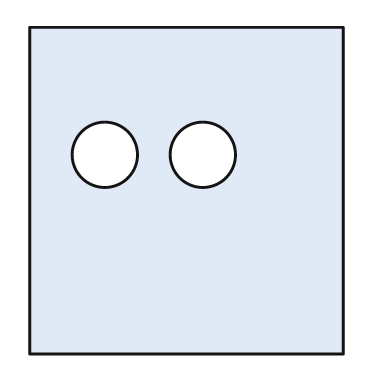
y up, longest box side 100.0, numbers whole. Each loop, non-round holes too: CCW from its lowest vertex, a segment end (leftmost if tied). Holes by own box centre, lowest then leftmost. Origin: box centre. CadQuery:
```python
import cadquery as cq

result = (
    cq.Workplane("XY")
    .moveTo(-48.0, -50.0)
    .lineTo(48.0, -50.0)
    .lineTo(48.0, 50.0)
    .lineTo(-48.0, 50.0)
    .close()
    .moveTo(-25.0, 11.0)
    .circle(10.0)
    .moveTo(5.0, 11.0)
    .circle(10.0)
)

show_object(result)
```